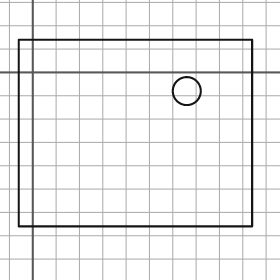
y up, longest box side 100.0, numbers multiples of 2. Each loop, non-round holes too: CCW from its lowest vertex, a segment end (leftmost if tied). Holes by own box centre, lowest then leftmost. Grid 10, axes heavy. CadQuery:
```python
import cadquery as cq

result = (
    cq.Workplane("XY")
    .moveTo(-6.0, -66.0)
    .lineTo(94.0, -66.0)
    .lineTo(94.0, 14.0)
    .lineTo(-6.0, 14.0)
    .close()
    .moveTo(66.0, -8.0)
    .circle(6.0)
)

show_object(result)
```